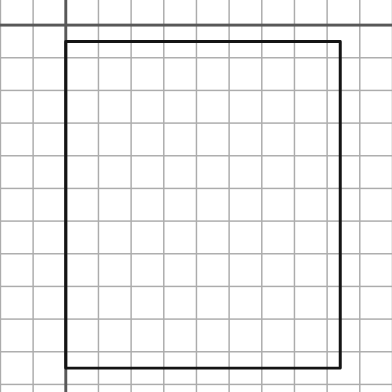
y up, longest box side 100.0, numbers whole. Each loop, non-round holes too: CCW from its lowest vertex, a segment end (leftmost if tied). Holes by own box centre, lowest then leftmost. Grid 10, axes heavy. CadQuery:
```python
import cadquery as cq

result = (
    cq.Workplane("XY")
    .moveTo(0.0, -105.0)
    .lineTo(84.0, -105.0)
    .lineTo(84.0, -5.0)
    .lineTo(0.0, -5.0)
    .close()
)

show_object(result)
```